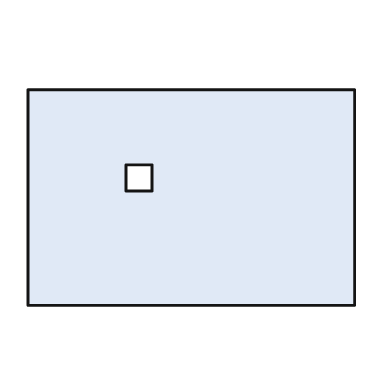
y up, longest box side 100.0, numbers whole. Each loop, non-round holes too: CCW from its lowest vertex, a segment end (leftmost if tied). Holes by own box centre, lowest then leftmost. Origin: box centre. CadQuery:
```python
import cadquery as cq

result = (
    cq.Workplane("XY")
    .moveTo(-50.0, -33.0)
    .lineTo(50.0, -33.0)
    .lineTo(50.0, 33.0)
    .lineTo(-50.0, 33.0)
    .close()
    .moveTo(-20.0, 2.0)
    .lineTo(-12.0, 2.0)
    .lineTo(-12.0, 10.0)
    .lineTo(-20.0, 10.0)
    .close()
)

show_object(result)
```